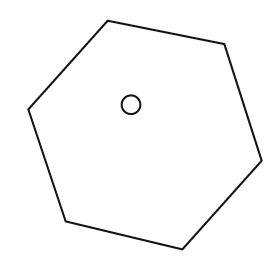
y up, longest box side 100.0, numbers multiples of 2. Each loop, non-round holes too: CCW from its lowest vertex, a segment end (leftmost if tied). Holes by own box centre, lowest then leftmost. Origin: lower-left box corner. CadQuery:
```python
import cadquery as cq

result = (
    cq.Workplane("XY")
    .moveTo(66.0, 0.0)
    .lineTo(100.0, 38.0)
    .lineTo(84.0, 88.0)
    .lineTo(34.0, 98.0)
    .lineTo(0.0, 60.0)
    .lineTo(16.0, 12.0)
    .close()
    .moveTo(44.0, 62.0)
    .circle(4.0)
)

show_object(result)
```